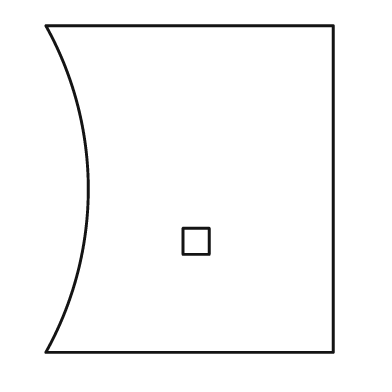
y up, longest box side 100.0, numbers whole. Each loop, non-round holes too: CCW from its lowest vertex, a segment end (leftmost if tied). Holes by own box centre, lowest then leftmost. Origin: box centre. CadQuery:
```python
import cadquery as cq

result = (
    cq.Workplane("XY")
    .moveTo(-44.0, -50.0)
    .lineTo(44.0, -50.0)
    .lineTo(44.0, 50.0)
    .lineTo(-44.0, 50.0)
    .threePointArc((-31.0, 0.0), (-44.0, -50.0))
    .close()
    .moveTo(-2.0, -20.0)
    .lineTo(6.0, -20.0)
    .lineTo(6.0, -12.0)
    .lineTo(-2.0, -12.0)
    .close()
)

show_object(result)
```